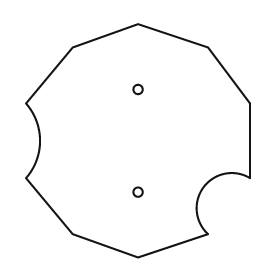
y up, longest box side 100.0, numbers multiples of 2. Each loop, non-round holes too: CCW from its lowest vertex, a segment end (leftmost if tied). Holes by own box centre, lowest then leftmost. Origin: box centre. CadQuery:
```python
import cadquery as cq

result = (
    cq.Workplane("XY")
    .moveTo(0.0, -50.0)
    .lineTo(30.0, -40.0)
    .threePointArc((28.0, -20.0), (48.0, -16.0))
    .lineTo(48.0, 16.0)
    .lineTo(30.0, 40.0)
    .lineTo(0.0, 50.0)
    .lineTo(-28.0, 40.0)
    .lineTo(-48.0, 16.0)
    .threePointArc((-42.0, 0.0), (-48.0, -16.0))
    .lineTo(-28.0, -40.0)
    .close()
    .moveTo(0.0, -22.0)
    .circle(2.0)
    .moveTo(0.0, 22.0)
    .circle(2.0)
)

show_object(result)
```